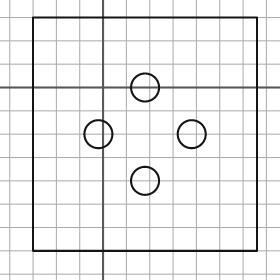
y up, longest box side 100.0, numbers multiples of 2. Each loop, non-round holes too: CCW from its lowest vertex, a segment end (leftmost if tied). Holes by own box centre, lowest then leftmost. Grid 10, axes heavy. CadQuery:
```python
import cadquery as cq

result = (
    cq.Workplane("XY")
    .moveTo(-30.0, -70.0)
    .lineTo(66.0, -70.0)
    .lineTo(66.0, 30.0)
    .lineTo(-30.0, 30.0)
    .close()
    .moveTo(18.0, -40.0)
    .circle(6.0)
    .moveTo(-2.0, -20.0)
    .circle(6.0)
    .moveTo(38.0, -20.0)
    .circle(6.0)
    .moveTo(18.0, 0.0)
    .circle(6.0)
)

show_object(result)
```